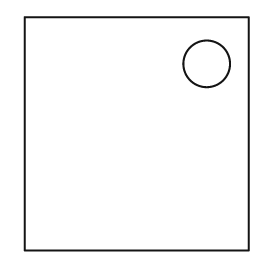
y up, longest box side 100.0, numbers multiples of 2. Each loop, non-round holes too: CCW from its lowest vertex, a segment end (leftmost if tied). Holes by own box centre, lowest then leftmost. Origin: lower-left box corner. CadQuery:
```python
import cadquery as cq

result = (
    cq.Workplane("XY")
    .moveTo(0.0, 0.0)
    .lineTo(96.0, 0.0)
    .lineTo(96.0, 100.0)
    .lineTo(0.0, 100.0)
    .close()
    .moveTo(78.0, 80.0)
    .circle(10.0)
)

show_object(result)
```